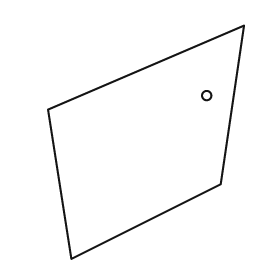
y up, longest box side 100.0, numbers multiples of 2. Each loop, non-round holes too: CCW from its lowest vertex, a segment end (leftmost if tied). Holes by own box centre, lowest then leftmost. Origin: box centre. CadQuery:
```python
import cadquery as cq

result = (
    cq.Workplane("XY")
    .moveTo(-32.0, -50.0)
    .lineTo(32.0, -18.0)
    .lineTo(42.0, 50.0)
    .lineTo(-42.0, 14.0)
    .close()
    .moveTo(26.0, 20.0)
    .circle(2.0)
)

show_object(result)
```